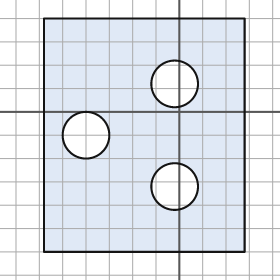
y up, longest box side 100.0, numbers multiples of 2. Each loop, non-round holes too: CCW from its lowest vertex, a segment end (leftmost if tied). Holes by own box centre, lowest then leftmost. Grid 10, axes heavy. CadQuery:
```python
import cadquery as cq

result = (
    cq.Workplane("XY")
    .moveTo(-58.0, -60.0)
    .lineTo(28.0, -60.0)
    .lineTo(28.0, 40.0)
    .lineTo(-58.0, 40.0)
    .close()
    .moveTo(-2.0, -32.0)
    .circle(10.0)
    .moveTo(-40.0, -10.0)
    .circle(10.0)
    .moveTo(-2.0, 12.0)
    .circle(10.0)
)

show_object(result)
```